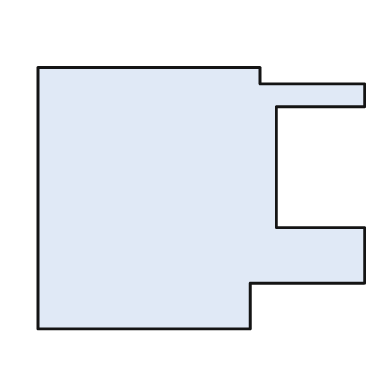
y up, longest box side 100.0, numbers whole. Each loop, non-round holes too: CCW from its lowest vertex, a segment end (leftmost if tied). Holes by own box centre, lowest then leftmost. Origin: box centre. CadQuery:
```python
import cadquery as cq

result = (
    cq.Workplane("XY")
    .moveTo(-50.0, -40.0)
    .lineTo(15.0, -40.0)
    .lineTo(15.0, -26.0)
    .lineTo(50.0, -26.0)
    .lineTo(50.0, -9.0)
    .lineTo(23.0, -9.0)
    .lineTo(23.0, 28.0)
    .lineTo(50.0, 28.0)
    .lineTo(50.0, 35.0)
    .lineTo(18.0, 35.0)
    .lineTo(18.0, 40.0)
    .lineTo(-50.0, 40.0)
    .close()
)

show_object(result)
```